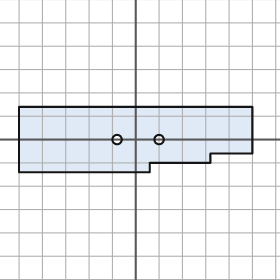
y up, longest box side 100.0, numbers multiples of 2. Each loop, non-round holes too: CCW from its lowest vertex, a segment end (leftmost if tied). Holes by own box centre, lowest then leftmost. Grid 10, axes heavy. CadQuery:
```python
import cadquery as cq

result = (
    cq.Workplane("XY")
    .moveTo(-50.0, -14.0)
    .lineTo(6.0, -14.0)
    .lineTo(6.0, -10.0)
    .lineTo(32.0, -10.0)
    .lineTo(32.0, -6.0)
    .lineTo(50.0, -6.0)
    .lineTo(50.0, 14.0)
    .lineTo(-50.0, 14.0)
    .close()
    .moveTo(-8.0, 0.0)
    .circle(2.0)
    .moveTo(10.0, 0.0)
    .circle(2.0)
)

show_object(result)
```